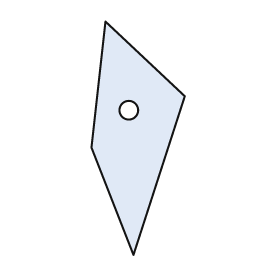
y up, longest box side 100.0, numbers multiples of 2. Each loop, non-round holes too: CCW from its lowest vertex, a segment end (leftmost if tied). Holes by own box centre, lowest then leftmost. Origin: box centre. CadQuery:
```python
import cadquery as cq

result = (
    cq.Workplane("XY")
    .moveTo(-2.0, -50.0)
    .lineTo(20.0, 18.0)
    .lineTo(-14.0, 50.0)
    .lineTo(-20.0, -4.0)
    .close()
    .moveTo(-4.0, 12.0)
    .circle(4.0)
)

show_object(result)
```